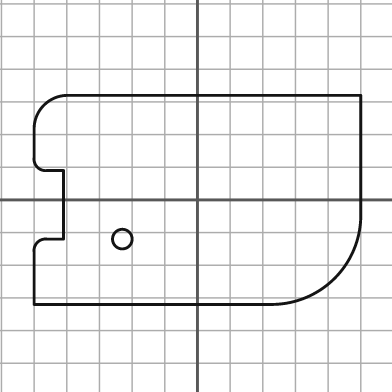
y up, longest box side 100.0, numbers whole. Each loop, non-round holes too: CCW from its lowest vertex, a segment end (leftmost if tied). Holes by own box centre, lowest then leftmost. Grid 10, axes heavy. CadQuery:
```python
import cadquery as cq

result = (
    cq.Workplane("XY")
    .moveTo(-50.0, -32.0)
    .lineTo(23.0, -32.0)
    .threePointArc((42.0, -24.0), (50.0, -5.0))
    .lineTo(50.0, 32.0)
    .lineTo(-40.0, 32.0)
    .threePointArc((-47.0, 29.0), (-50.0, 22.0))
    .lineTo(-50.0, 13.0)
    .threePointArc((-49.0, 10.0), (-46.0, 9.0))
    .lineTo(-41.0, 9.0)
    .lineTo(-41.0, -12.0)
    .lineTo(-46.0, -12.0)
    .threePointArc((-49.0, -13.0), (-50.0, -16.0))
    .close()
    .moveTo(-23.0, -12.0)
    .circle(3.0)
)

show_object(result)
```